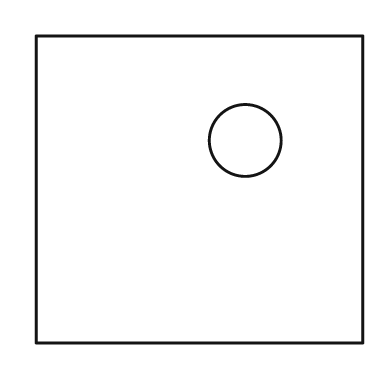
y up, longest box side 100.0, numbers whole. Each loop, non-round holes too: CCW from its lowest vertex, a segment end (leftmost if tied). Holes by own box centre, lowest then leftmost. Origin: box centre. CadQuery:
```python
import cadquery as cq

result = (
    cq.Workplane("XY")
    .moveTo(-50.0, -47.0)
    .lineTo(50.0, -47.0)
    .lineTo(50.0, 47.0)
    .lineTo(-50.0, 47.0)
    .close()
    .moveTo(14.0, 15.0)
    .circle(11.0)
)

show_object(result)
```